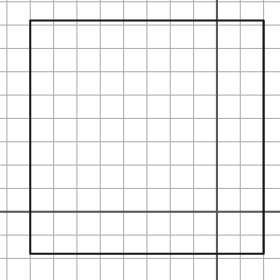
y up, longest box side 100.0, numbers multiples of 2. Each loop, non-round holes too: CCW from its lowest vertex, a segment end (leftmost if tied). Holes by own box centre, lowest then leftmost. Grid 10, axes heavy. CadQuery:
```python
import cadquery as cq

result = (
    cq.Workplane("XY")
    .moveTo(-80.0, -18.0)
    .lineTo(20.0, -18.0)
    .lineTo(20.0, 82.0)
    .lineTo(-80.0, 82.0)
    .close()
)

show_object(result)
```